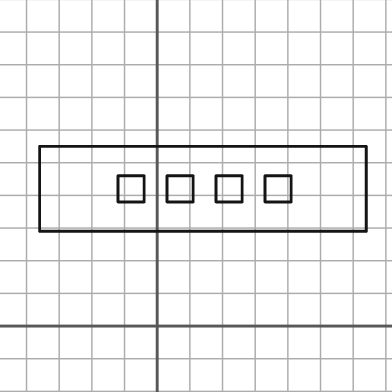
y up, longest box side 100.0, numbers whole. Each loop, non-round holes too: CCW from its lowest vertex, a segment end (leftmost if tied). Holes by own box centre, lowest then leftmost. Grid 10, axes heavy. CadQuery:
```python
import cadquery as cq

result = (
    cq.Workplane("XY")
    .moveTo(-36.0, 29.0)
    .lineTo(64.0, 29.0)
    .lineTo(64.0, 55.0)
    .lineTo(-36.0, 55.0)
    .close()
    .moveTo(-12.0, 38.0)
    .lineTo(-4.0, 38.0)
    .lineTo(-4.0, 46.0)
    .lineTo(-12.0, 46.0)
    .close()
    .moveTo(3.0, 38.0)
    .lineTo(11.0, 38.0)
    .lineTo(11.0, 46.0)
    .lineTo(3.0, 46.0)
    .close()
    .moveTo(18.0, 38.0)
    .lineTo(26.0, 38.0)
    .lineTo(26.0, 46.0)
    .lineTo(18.0, 46.0)
    .close()
    .moveTo(33.0, 38.0)
    .lineTo(41.0, 38.0)
    .lineTo(41.0, 46.0)
    .lineTo(33.0, 46.0)
    .close()
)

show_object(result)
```